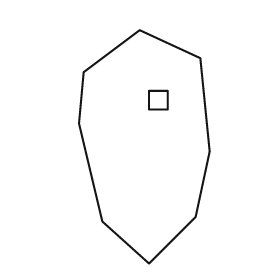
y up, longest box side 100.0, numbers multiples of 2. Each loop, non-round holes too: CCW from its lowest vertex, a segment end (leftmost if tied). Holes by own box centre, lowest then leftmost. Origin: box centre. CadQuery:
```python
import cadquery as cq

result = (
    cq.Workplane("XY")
    .moveTo(2.0, -50.0)
    .lineTo(22.0, -30.0)
    .lineTo(28.0, -2.0)
    .lineTo(24.0, 38.0)
    .lineTo(-2.0, 50.0)
    .lineTo(-26.0, 32.0)
    .lineTo(-28.0, 10.0)
    .lineTo(-18.0, -32.0)
    .close()
    .moveTo(2.0, 16.0)
    .lineTo(10.0, 16.0)
    .lineTo(10.0, 24.0)
    .lineTo(2.0, 24.0)
    .close()
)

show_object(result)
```